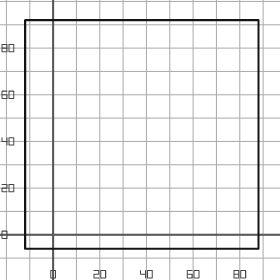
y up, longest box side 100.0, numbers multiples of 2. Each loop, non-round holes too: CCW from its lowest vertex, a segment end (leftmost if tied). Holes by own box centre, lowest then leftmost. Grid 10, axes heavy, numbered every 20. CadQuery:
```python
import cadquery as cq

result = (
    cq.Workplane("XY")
    .moveTo(-12.0, -6.0)
    .lineTo(88.0, -6.0)
    .lineTo(88.0, 92.0)
    .lineTo(-12.0, 92.0)
    .close()
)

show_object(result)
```